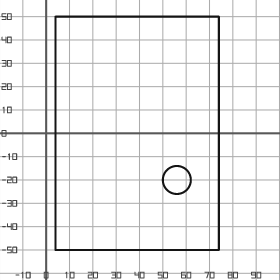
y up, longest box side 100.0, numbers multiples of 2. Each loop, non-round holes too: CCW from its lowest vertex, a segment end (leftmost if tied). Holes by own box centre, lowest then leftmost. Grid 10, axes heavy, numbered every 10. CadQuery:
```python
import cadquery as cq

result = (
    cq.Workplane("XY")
    .moveTo(4.0, -50.0)
    .lineTo(74.0, -50.0)
    .lineTo(74.0, 50.0)
    .lineTo(4.0, 50.0)
    .close()
    .moveTo(56.0, -20.0)
    .circle(6.0)
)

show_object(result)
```